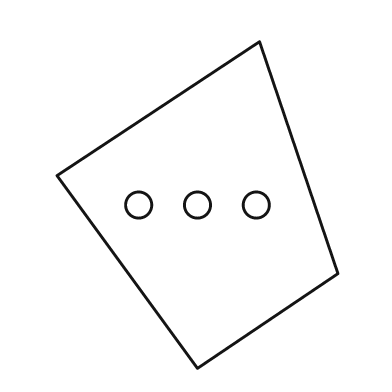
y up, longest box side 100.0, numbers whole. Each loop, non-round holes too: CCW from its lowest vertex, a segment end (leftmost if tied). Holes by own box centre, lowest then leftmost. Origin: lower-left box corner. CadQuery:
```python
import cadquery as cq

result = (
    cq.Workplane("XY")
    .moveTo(43.0, 0.0)
    .lineTo(86.0, 29.0)
    .lineTo(62.0, 100.0)
    .lineTo(0.0, 59.0)
    .close()
    .moveTo(25.0, 50.0)
    .circle(4.0)
    .moveTo(43.0, 50.0)
    .circle(4.0)
    .moveTo(61.0, 50.0)
    .circle(4.0)
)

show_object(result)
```